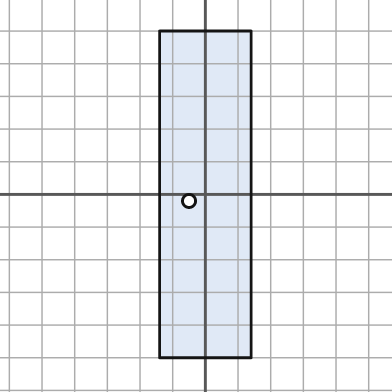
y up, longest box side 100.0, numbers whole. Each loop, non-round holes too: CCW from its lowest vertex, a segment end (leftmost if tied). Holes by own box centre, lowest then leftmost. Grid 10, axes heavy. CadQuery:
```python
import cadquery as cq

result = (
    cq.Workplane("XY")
    .moveTo(-14.0, -50.0)
    .lineTo(14.0, -50.0)
    .lineTo(14.0, 50.0)
    .lineTo(-14.0, 50.0)
    .close()
    .moveTo(-5.0, -2.0)
    .circle(2.0)
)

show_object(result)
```